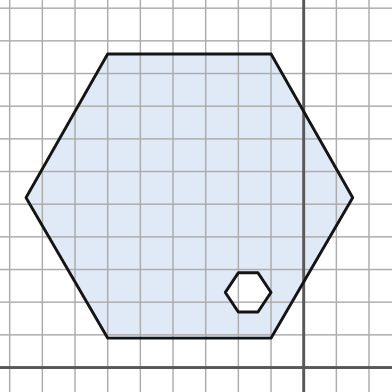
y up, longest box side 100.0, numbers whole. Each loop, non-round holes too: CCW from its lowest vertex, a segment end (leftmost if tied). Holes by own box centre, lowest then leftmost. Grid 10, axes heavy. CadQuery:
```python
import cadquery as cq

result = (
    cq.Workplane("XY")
    .moveTo(-60.0, 9.0)
    .lineTo(-10.0, 9.0)
    .lineTo(15.0, 52.0)
    .lineTo(-10.0, 96.0)
    .lineTo(-60.0, 96.0)
    .lineTo(-85.0, 52.0)
    .close()
    .moveTo(-20.0, 17.0)
    .lineTo(-14.0, 17.0)
    .lineTo(-10.0, 23.0)
    .lineTo(-14.0, 29.0)
    .lineTo(-20.0, 29.0)
    .lineTo(-24.0, 23.0)
    .close()
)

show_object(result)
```